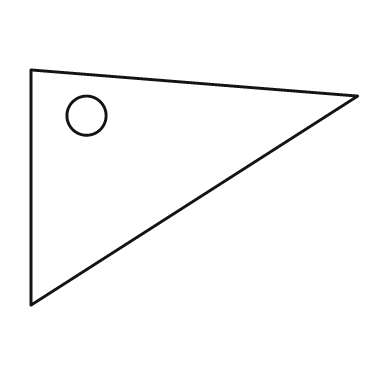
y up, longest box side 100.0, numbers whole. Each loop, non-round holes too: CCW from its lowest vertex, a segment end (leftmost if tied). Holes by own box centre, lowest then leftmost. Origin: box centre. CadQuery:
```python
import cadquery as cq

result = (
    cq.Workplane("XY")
    .moveTo(-50.0, -36.0)
    .lineTo(50.0, 28.0)
    .lineTo(-50.0, 36.0)
    .close()
    .moveTo(-33.0, 22.0)
    .circle(6.0)
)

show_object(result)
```